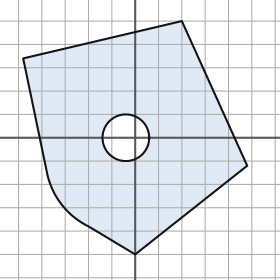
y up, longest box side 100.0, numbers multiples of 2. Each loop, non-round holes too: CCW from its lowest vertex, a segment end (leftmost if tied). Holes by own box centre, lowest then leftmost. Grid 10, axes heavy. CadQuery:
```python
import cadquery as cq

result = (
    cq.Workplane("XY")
    .moveTo(0.0, -50.0)
    .lineTo(48.0, -12.0)
    .lineTo(20.0, 50.0)
    .lineTo(-48.0, 34.0)
    .lineTo(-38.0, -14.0)
    .threePointArc((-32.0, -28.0), (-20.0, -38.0))
    .close()
    .moveTo(-4.0, 0.0)
    .circle(10.0)
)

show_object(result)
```